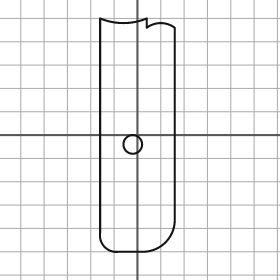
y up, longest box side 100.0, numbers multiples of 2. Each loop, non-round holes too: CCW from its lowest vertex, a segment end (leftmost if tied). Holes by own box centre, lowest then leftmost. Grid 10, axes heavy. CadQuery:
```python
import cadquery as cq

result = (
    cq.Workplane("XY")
    .moveTo(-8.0, -50.0)
    .lineTo(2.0, -50.0)
    .threePointArc((12.0, -46.0), (16.0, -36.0))
    .lineTo(16.0, 46.0)
    .threePointArc((10.0, 48.0), (4.0, 46.0))
    .lineTo(4.0, 50.0)
    .threePointArc((-6.0, 48.0), (-16.0, 50.0))
    .lineTo(-16.0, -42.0)
    .threePointArc((-14.0, -48.0), (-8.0, -50.0))
    .close()
    .moveTo(-2.0, -4.0)
    .circle(4.0)
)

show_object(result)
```